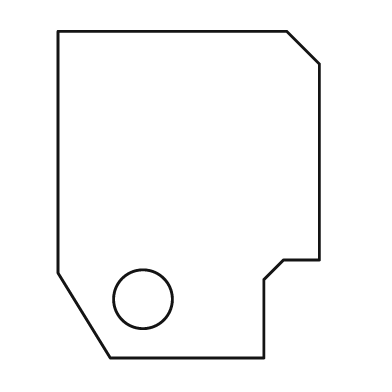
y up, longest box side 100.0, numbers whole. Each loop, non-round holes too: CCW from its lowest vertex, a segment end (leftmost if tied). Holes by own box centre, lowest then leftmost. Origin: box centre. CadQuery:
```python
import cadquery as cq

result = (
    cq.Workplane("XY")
    .moveTo(-24.0, -50.0)
    .lineTo(23.0, -50.0)
    .lineTo(23.0, -26.0)
    .lineTo(29.0, -20.0)
    .lineTo(40.0, -20.0)
    .lineTo(40.0, 40.0)
    .lineTo(30.0, 50.0)
    .lineTo(-40.0, 50.0)
    .lineTo(-40.0, -24.0)
    .close()
    .moveTo(-14.0, -32.0)
    .circle(9.0)
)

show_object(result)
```